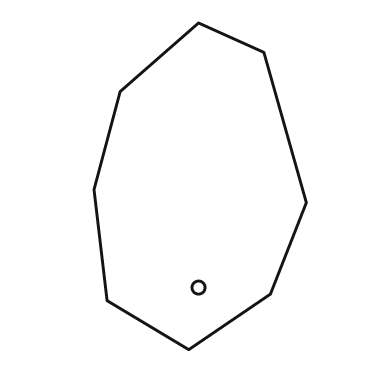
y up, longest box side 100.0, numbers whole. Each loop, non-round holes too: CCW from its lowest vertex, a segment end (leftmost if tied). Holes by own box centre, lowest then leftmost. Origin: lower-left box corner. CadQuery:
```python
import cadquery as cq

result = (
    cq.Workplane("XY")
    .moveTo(29.0, 0.0)
    .lineTo(54.0, 17.0)
    .lineTo(65.0, 45.0)
    .lineTo(52.0, 91.0)
    .lineTo(32.0, 100.0)
    .lineTo(8.0, 79.0)
    .lineTo(0.0, 49.0)
    .lineTo(4.0, 15.0)
    .close()
    .moveTo(32.0, 19.0)
    .circle(2.0)
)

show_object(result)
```